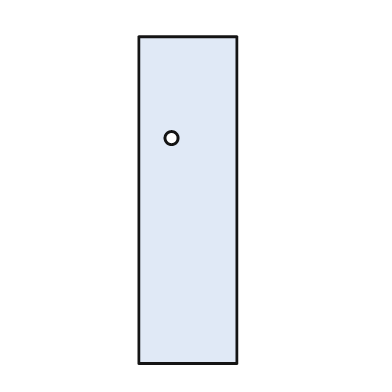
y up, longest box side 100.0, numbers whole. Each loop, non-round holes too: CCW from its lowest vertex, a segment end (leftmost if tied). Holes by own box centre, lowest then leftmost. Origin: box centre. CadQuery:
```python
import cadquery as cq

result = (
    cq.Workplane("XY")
    .moveTo(-15.0, -50.0)
    .lineTo(15.0, -50.0)
    .lineTo(15.0, 50.0)
    .lineTo(-15.0, 50.0)
    .close()
    .moveTo(-5.0, 19.0)
    .circle(2.0)
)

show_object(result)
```